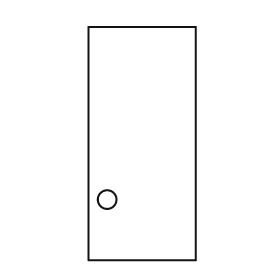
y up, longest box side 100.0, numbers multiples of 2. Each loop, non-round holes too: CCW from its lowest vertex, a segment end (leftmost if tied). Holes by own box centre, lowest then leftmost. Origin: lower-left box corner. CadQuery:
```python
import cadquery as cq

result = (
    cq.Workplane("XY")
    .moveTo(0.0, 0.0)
    .lineTo(46.0, 0.0)
    .lineTo(46.0, 100.0)
    .lineTo(0.0, 100.0)
    .close()
    .moveTo(8.0, 26.0)
    .circle(4.0)
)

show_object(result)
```